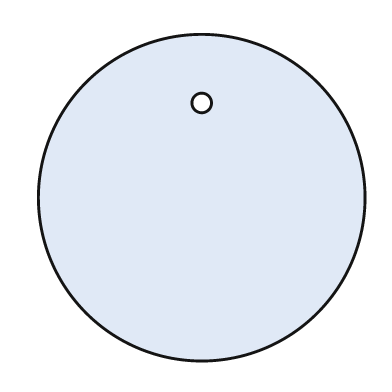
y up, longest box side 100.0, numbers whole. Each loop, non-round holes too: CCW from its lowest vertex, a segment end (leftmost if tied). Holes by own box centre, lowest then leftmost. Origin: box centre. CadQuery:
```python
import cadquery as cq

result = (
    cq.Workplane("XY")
    .moveTo(0.0, 0.0)
    .circle(50.0)
    .moveTo(0.0, 29.0)
    .circle(3.0)
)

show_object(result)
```